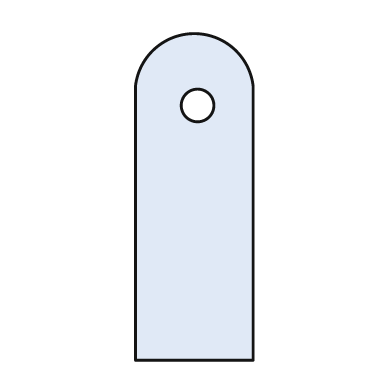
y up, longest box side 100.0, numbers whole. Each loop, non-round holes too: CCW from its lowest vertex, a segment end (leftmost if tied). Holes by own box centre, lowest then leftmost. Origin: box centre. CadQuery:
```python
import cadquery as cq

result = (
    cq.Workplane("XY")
    .moveTo(-18.0, -50.0)
    .lineTo(18.0, -50.0)
    .lineTo(18.0, 34.0)
    .threePointArc((0.0, 50.0), (-18.0, 34.0))
    .close()
    .moveTo(1.0, 28.0)
    .circle(5.0)
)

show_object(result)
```